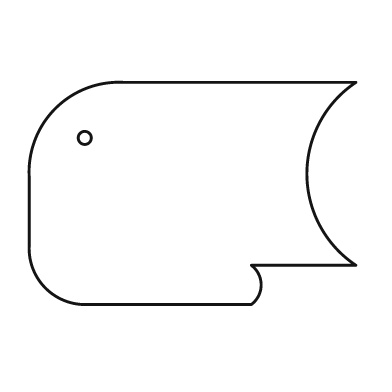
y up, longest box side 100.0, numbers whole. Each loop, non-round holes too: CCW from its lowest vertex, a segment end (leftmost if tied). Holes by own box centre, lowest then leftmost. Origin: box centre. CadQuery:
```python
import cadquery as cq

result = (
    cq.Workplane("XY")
    .moveTo(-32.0, -34.0)
    .lineTo(18.0, -34.0)
    .threePointArc((21.0, -28.0), (18.0, -22.0))
    .lineTo(50.0, -22.0)
    .threePointArc((35.0, 6.0), (50.0, 34.0))
    .lineTo(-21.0, 34.0)
    .threePointArc((-42.0, 26.0), (-50.0, 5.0))
    .lineTo(-50.0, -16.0)
    .threePointArc((-45.0, -29.0), (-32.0, -34.0))
    .close()
    .moveTo(-33.0, 17.0)
    .circle(2.0)
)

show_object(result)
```